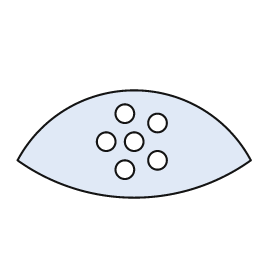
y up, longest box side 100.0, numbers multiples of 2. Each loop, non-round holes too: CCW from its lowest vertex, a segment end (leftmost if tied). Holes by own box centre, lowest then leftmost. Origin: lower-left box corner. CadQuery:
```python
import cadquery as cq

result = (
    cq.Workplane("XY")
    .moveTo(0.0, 16.0)
    .threePointArc((50.0, 0.0), (100.0, 16.0))
    .threePointArc((50.0, 46.0), (0.0, 16.0))
    .close()
    .moveTo(46.0, 12.0)
    .circle(4.0)
    .moveTo(60.0, 16.0)
    .circle(4.0)
    .moveTo(38.0, 24.0)
    .circle(4.0)
    .moveTo(50.0, 24.0)
    .circle(4.0)
    .moveTo(60.0, 32.0)
    .circle(4.0)
    .moveTo(46.0, 36.0)
    .circle(4.0)
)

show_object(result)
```